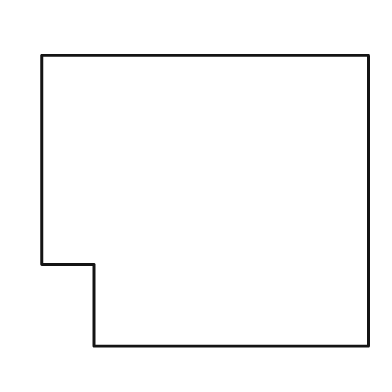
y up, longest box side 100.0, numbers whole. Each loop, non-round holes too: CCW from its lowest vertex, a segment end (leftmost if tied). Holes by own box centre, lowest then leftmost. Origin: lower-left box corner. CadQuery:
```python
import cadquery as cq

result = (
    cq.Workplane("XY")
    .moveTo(16.0, 0.0)
    .lineTo(100.0, 0.0)
    .lineTo(100.0, 89.0)
    .lineTo(0.0, 89.0)
    .lineTo(0.0, 25.0)
    .lineTo(16.0, 25.0)
    .close()
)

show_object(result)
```